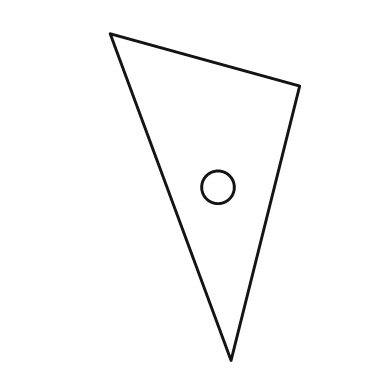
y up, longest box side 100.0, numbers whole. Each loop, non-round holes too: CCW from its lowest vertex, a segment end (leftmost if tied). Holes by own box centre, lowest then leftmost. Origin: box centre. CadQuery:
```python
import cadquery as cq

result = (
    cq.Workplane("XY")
    .moveTo(8.0, -50.0)
    .lineTo(29.0, 34.0)
    .lineTo(-29.0, 50.0)
    .close()
    .moveTo(4.0, 3.0)
    .circle(5.0)
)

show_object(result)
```